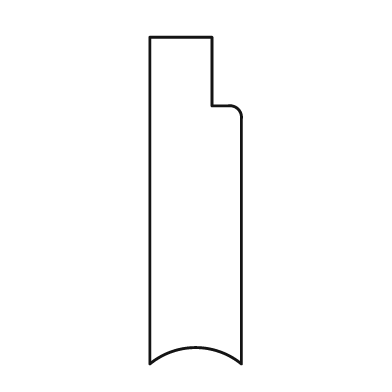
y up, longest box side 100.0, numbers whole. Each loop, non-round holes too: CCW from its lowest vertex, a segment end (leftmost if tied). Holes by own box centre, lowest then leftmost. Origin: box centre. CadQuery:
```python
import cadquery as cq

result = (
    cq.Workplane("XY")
    .moveTo(-14.0, -50.0)
    .threePointArc((0.0, -45.0), (14.0, -50.0))
    .lineTo(14.0, 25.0)
    .threePointArc((13.0, 28.0), (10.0, 29.0))
    .lineTo(5.0, 29.0)
    .lineTo(5.0, 50.0)
    .lineTo(-14.0, 50.0)
    .close()
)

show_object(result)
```